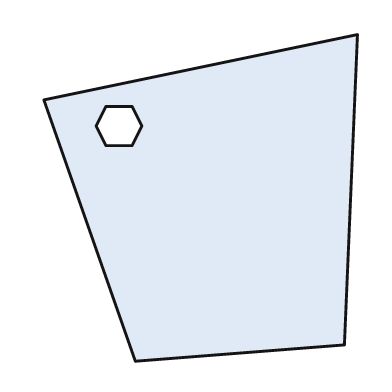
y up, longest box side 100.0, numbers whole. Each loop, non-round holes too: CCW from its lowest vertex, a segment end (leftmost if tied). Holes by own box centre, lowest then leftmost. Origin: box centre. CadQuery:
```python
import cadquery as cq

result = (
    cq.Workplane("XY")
    .moveTo(-20.0, -50.0)
    .lineTo(44.0, -45.0)
    .lineTo(48.0, 50.0)
    .lineTo(-48.0, 30.0)
    .close()
    .moveTo(-29.0, 16.0)
    .lineTo(-21.0, 16.0)
    .lineTo(-18.0, 22.0)
    .lineTo(-21.0, 28.0)
    .lineTo(-29.0, 28.0)
    .lineTo(-32.0, 22.0)
    .close()
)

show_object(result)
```